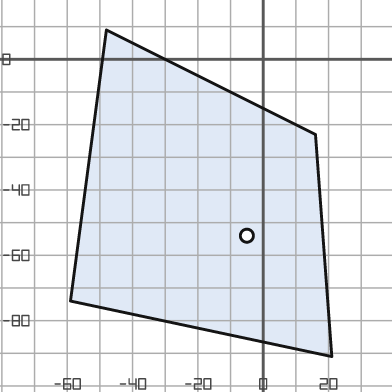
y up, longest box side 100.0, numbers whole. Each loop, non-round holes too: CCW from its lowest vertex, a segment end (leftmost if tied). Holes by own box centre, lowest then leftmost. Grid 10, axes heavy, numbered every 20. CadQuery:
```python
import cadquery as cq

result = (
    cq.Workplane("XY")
    .moveTo(21.0, -91.0)
    .lineTo(16.0, -23.0)
    .lineTo(-48.0, 9.0)
    .lineTo(-59.0, -74.0)
    .close()
    .moveTo(-5.0, -54.0)
    .circle(2.0)
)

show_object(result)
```